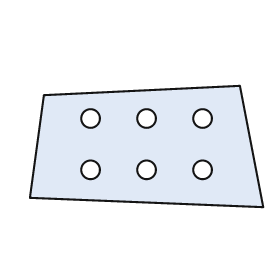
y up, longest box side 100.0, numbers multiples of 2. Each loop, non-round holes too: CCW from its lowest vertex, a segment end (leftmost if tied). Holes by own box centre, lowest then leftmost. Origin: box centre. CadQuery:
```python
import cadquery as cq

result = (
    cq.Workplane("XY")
    .moveTo(50.0, -26.0)
    .lineTo(40.0, 26.0)
    .lineTo(-44.0, 22.0)
    .lineTo(-50.0, -22.0)
    .close()
    .moveTo(-24.0, -10.0)
    .circle(4.0)
    .moveTo(0.0, -10.0)
    .circle(4.0)
    .moveTo(24.0, -10.0)
    .circle(4.0)
    .moveTo(-24.0, 12.0)
    .circle(4.0)
    .moveTo(0.0, 12.0)
    .circle(4.0)
    .moveTo(24.0, 12.0)
    .circle(4.0)
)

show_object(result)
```